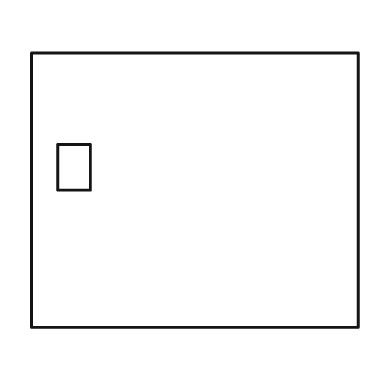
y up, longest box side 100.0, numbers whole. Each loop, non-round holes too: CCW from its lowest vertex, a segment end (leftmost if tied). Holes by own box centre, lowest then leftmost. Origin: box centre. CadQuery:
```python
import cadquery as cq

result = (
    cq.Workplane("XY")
    .moveTo(-50.0, -42.0)
    .lineTo(50.0, -42.0)
    .lineTo(50.0, 42.0)
    .lineTo(-50.0, 42.0)
    .close()
    .moveTo(-42.0, 0.0)
    .lineTo(-32.0, 0.0)
    .lineTo(-32.0, 14.0)
    .lineTo(-42.0, 14.0)
    .close()
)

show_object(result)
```